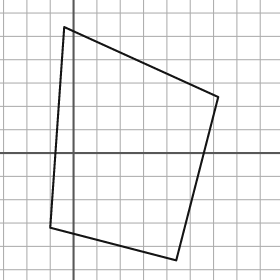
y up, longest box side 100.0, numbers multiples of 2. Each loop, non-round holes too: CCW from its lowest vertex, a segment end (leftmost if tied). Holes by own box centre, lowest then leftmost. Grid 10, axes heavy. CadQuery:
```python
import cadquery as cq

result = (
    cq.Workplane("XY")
    .moveTo(44.0, -46.0)
    .lineTo(62.0, 24.0)
    .lineTo(-4.0, 54.0)
    .lineTo(-10.0, -32.0)
    .close()
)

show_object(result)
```